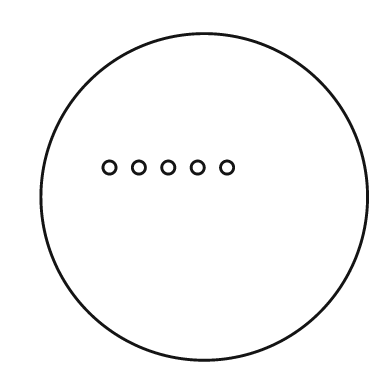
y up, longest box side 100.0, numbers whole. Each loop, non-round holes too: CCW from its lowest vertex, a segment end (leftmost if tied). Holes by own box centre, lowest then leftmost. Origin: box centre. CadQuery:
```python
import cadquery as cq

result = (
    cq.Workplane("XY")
    .moveTo(0.0, 0.0)
    .circle(50.0)
    .moveTo(-29.0, 9.0)
    .circle(2.0)
    .moveTo(-20.0, 9.0)
    .circle(2.0)
    .moveTo(-11.0, 9.0)
    .circle(2.0)
    .moveTo(-2.0, 9.0)
    .circle(2.0)
    .moveTo(7.0, 9.0)
    .circle(2.0)
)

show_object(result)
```